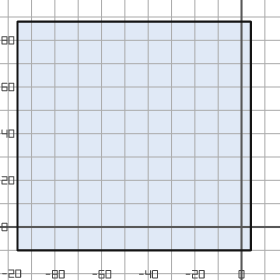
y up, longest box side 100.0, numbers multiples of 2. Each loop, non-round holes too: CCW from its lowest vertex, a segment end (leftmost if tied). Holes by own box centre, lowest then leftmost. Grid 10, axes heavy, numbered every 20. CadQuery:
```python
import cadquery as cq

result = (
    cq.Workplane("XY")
    .moveTo(-96.0, -10.0)
    .lineTo(4.0, -10.0)
    .lineTo(4.0, 88.0)
    .lineTo(-96.0, 88.0)
    .close()
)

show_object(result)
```